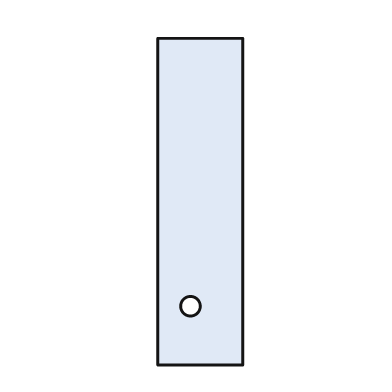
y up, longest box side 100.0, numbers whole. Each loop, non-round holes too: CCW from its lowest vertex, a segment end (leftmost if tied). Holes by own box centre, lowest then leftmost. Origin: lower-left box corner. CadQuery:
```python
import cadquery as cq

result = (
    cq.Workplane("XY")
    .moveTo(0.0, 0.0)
    .lineTo(26.0, 0.0)
    .lineTo(26.0, 100.0)
    .lineTo(0.0, 100.0)
    .close()
    .moveTo(10.0, 18.0)
    .circle(3.0)
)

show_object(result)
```